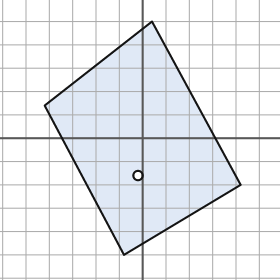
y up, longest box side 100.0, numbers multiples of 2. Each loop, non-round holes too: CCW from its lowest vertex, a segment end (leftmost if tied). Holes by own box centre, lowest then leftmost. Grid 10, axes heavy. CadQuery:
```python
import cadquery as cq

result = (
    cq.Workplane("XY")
    .moveTo(-8.0, -50.0)
    .lineTo(42.0, -20.0)
    .lineTo(4.0, 50.0)
    .lineTo(-42.0, 14.0)
    .close()
    .moveTo(-2.0, -16.0)
    .circle(2.0)
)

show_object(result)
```